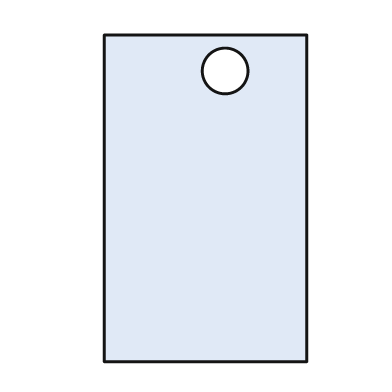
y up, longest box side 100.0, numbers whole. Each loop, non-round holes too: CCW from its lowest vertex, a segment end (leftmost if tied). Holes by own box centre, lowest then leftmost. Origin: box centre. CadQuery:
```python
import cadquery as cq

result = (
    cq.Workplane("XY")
    .moveTo(-31.0, -50.0)
    .lineTo(31.0, -50.0)
    .lineTo(31.0, 50.0)
    .lineTo(-31.0, 50.0)
    .close()
    .moveTo(6.0, 39.0)
    .circle(7.0)
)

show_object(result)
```